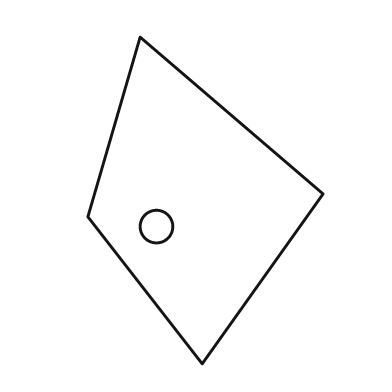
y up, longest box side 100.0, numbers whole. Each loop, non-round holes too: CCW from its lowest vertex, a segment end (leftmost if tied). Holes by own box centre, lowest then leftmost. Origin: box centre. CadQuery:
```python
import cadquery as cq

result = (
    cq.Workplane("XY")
    .moveTo(-1.0, -50.0)
    .lineTo(36.0, 2.0)
    .lineTo(-20.0, 50.0)
    .lineTo(-36.0, -5.0)
    .close()
    .moveTo(-15.0, -8.0)
    .circle(5.0)
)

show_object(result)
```